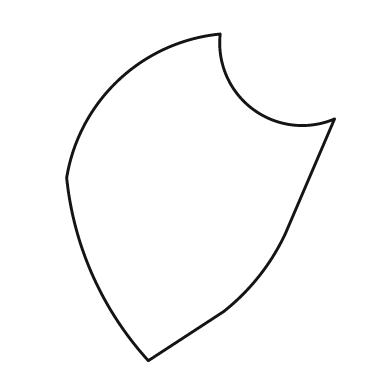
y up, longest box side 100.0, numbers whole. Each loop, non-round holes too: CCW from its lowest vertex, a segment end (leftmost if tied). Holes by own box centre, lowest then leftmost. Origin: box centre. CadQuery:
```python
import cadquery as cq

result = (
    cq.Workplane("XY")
    .moveTo(-16.0, -50.0)
    .lineTo(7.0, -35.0)
    .threePointArc((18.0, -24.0), (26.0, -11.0))
    .lineTo(41.0, 24.0)
    .threePointArc((16.0, 27.0), (6.0, 50.0))
    .threePointArc((-25.0, 36.0), (-41.0, 6.0))
    .threePointArc((-33.0, -24.0), (-16.0, -50.0))
    .close()
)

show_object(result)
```